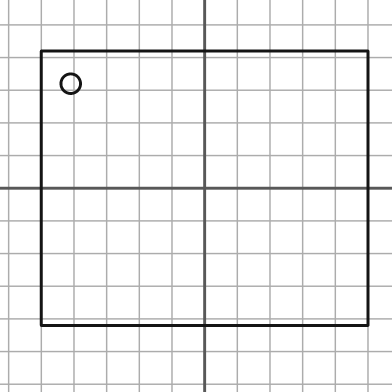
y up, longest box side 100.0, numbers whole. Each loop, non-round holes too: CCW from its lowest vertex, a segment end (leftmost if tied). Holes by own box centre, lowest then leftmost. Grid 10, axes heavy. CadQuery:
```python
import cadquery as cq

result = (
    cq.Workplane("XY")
    .moveTo(-50.0, -42.0)
    .lineTo(50.0, -42.0)
    .lineTo(50.0, 42.0)
    .lineTo(-50.0, 42.0)
    .close()
    .moveTo(-41.0, 32.0)
    .circle(3.0)
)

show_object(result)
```